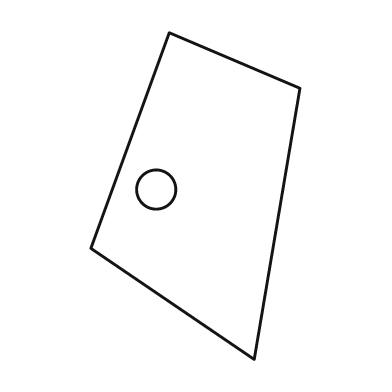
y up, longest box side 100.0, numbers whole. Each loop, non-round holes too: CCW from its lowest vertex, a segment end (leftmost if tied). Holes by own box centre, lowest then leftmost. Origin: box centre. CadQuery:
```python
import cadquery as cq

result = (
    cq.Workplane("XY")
    .moveTo(18.0, -50.0)
    .lineTo(32.0, 33.0)
    .lineTo(-8.0, 50.0)
    .lineTo(-32.0, -16.0)
    .close()
    .moveTo(-12.0, 2.0)
    .circle(6.0)
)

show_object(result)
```